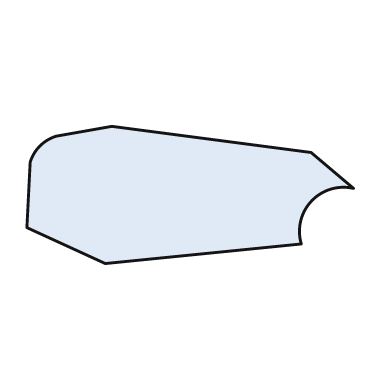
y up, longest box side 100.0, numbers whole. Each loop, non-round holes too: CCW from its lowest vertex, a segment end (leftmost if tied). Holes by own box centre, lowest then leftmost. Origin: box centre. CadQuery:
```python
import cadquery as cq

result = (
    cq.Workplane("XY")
    .moveTo(-26.0, -21.0)
    .lineTo(34.0, -15.0)
    .threePointArc((37.0, -2.0), (50.0, 2.0))
    .lineTo(37.0, 13.0)
    .lineTo(-24.0, 21.0)
    .lineTo(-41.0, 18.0)
    .threePointArc((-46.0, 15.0), (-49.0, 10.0))
    .lineTo(-50.0, -10.0)
    .close()
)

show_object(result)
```